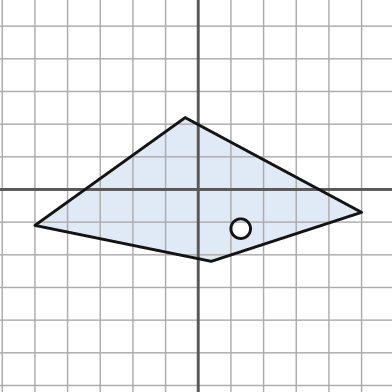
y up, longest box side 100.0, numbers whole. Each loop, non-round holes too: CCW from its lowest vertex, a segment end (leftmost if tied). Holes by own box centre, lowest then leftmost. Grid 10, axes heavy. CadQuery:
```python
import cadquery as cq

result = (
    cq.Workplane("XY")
    .moveTo(4.0, -22.0)
    .lineTo(50.0, -7.0)
    .lineTo(-4.0, 22.0)
    .lineTo(-50.0, -11.0)
    .close()
    .moveTo(13.0, -12.0)
    .circle(3.0)
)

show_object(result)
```